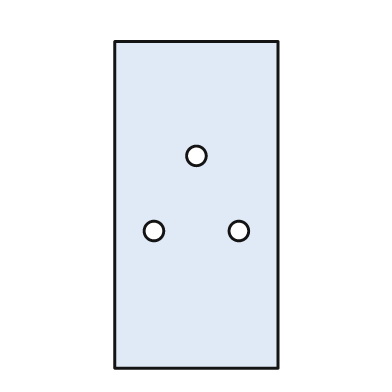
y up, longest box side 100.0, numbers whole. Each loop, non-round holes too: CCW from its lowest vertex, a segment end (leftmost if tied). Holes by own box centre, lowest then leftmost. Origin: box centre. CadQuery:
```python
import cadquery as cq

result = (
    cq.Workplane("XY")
    .moveTo(-25.0, -50.0)
    .lineTo(25.0, -50.0)
    .lineTo(25.0, 50.0)
    .lineTo(-25.0, 50.0)
    .close()
    .moveTo(-13.0, -8.0)
    .circle(3.0)
    .moveTo(13.0, -8.0)
    .circle(3.0)
    .moveTo(0.0, 15.0)
    .circle(3.0)
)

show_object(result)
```